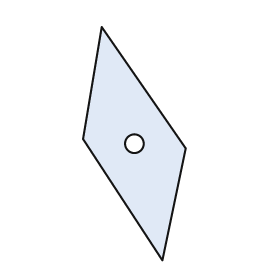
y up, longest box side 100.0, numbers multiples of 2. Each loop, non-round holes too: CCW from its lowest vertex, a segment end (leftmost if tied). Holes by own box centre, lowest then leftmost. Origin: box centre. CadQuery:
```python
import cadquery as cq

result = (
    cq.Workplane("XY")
    .moveTo(12.0, -50.0)
    .lineTo(22.0, -2.0)
    .lineTo(-14.0, 50.0)
    .lineTo(-22.0, 2.0)
    .close()
    .moveTo(0.0, 0.0)
    .circle(4.0)
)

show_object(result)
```